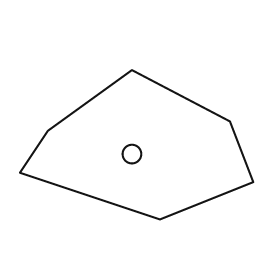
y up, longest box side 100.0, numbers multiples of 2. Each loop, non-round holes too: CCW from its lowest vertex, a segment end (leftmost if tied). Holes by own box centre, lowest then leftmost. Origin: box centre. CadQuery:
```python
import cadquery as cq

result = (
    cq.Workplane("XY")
    .moveTo(10.0, -32.0)
    .lineTo(50.0, -16.0)
    .lineTo(40.0, 10.0)
    .lineTo(-2.0, 32.0)
    .lineTo(-38.0, 6.0)
    .lineTo(-50.0, -12.0)
    .close()
    .moveTo(-2.0, -4.0)
    .circle(4.0)
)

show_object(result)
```